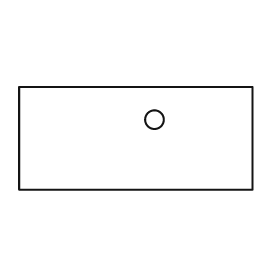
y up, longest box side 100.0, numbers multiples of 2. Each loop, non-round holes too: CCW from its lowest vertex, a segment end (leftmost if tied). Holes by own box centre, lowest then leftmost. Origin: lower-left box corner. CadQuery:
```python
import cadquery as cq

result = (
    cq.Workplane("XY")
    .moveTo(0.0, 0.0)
    .lineTo(100.0, 0.0)
    .lineTo(100.0, 44.0)
    .lineTo(0.0, 44.0)
    .close()
    .moveTo(58.0, 30.0)
    .circle(4.0)
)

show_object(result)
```